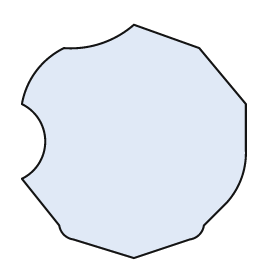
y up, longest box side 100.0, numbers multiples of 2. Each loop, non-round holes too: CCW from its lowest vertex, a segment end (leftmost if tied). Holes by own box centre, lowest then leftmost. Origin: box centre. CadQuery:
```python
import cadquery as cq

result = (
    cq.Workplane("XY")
    .moveTo(0.0, -50.0)
    .lineTo(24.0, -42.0)
    .threePointArc((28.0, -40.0), (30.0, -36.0))
    .lineTo(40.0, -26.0)
    .threePointArc((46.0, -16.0), (48.0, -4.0))
    .lineTo(48.0, 16.0)
    .lineTo(28.0, 40.0)
    .lineTo(0.0, 50.0)
    .threePointArc((-14.0, 42.0), (-30.0, 40.0))
    .threePointArc((-42.0, 30.0), (-48.0, 16.0))
    .threePointArc((-38.0, 0.0), (-48.0, -16.0))
    .lineTo(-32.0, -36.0)
    .threePointArc((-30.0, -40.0), (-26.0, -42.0))
    .close()
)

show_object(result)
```